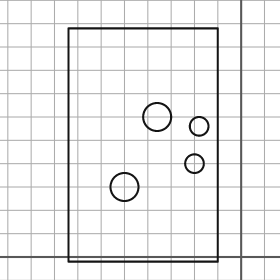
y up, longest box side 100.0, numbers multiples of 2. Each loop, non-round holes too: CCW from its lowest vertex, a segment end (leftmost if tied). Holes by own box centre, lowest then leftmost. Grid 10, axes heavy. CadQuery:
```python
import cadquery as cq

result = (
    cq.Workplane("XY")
    .moveTo(-74.0, -2.0)
    .lineTo(-10.0, -2.0)
    .lineTo(-10.0, 98.0)
    .lineTo(-74.0, 98.0)
    .close()
    .moveTo(-50.0, 30.0)
    .circle(6.0)
    .moveTo(-20.0, 40.0)
    .circle(4.0)
    .moveTo(-18.0, 56.0)
    .circle(4.0)
    .moveTo(-36.0, 60.0)
    .circle(6.0)
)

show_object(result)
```